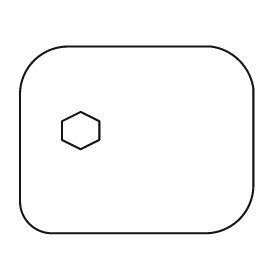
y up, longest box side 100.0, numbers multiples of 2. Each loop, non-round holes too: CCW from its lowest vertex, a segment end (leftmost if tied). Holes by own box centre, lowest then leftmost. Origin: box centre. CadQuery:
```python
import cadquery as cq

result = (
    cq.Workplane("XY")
    .moveTo(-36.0, -40.0)
    .lineTo(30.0, -40.0)
    .threePointArc((44.0, -34.0), (50.0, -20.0))
    .lineTo(50.0, 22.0)
    .threePointArc((44.0, 34.0), (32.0, 40.0))
    .lineTo(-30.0, 40.0)
    .threePointArc((-44.0, 34.0), (-50.0, 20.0))
    .lineTo(-50.0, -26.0)
    .threePointArc((-46.0, -36.0), (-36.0, -40.0))
    .close()
    .moveTo(-24.0, -4.0)
    .lineTo(-16.0, 0.0)
    .lineTo(-16.0, 8.0)
    .lineTo(-24.0, 12.0)
    .lineTo(-32.0, 8.0)
    .lineTo(-32.0, 0.0)
    .close()
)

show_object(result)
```